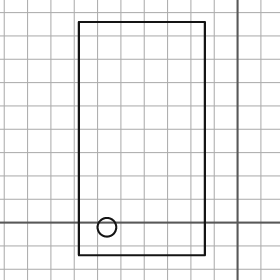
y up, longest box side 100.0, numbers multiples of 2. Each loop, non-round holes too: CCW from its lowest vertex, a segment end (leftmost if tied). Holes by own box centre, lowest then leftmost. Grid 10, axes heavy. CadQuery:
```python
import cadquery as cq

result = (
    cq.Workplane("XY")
    .moveTo(-68.0, -14.0)
    .lineTo(-14.0, -14.0)
    .lineTo(-14.0, 86.0)
    .lineTo(-68.0, 86.0)
    .close()
    .moveTo(-56.0, -2.0)
    .circle(4.0)
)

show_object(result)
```